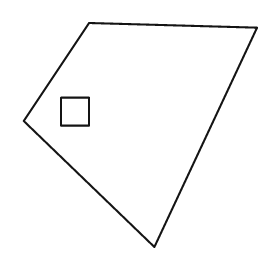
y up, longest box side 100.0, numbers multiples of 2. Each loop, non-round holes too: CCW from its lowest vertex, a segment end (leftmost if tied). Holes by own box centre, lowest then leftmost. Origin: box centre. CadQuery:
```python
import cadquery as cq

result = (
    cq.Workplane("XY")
    .moveTo(6.0, -48.0)
    .lineTo(50.0, 46.0)
    .lineTo(-22.0, 48.0)
    .lineTo(-50.0, 6.0)
    .close()
    .moveTo(-34.0, 4.0)
    .lineTo(-22.0, 4.0)
    .lineTo(-22.0, 16.0)
    .lineTo(-34.0, 16.0)
    .close()
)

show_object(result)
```